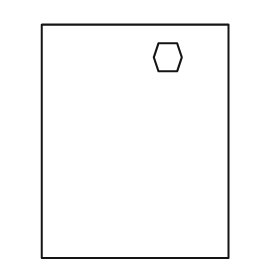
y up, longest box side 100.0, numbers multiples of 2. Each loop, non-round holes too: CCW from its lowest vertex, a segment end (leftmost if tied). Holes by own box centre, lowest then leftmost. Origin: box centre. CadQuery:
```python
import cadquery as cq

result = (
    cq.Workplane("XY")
    .moveTo(-40.0, -50.0)
    .lineTo(40.0, -50.0)
    .lineTo(40.0, 50.0)
    .lineTo(-40.0, 50.0)
    .close()
    .moveTo(10.0, 30.0)
    .lineTo(18.0, 30.0)
    .lineTo(20.0, 36.0)
    .lineTo(18.0, 42.0)
    .lineTo(10.0, 42.0)
    .lineTo(8.0, 36.0)
    .close()
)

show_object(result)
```